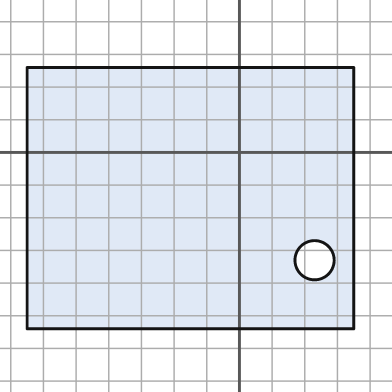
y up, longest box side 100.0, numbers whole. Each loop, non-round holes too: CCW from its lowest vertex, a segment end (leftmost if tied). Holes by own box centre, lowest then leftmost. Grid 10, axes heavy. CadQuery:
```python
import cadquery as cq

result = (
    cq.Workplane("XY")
    .moveTo(-65.0, -54.0)
    .lineTo(35.0, -54.0)
    .lineTo(35.0, 26.0)
    .lineTo(-65.0, 26.0)
    .close()
    .moveTo(23.0, -33.0)
    .circle(6.0)
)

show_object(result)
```